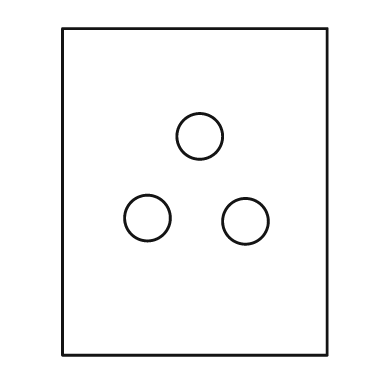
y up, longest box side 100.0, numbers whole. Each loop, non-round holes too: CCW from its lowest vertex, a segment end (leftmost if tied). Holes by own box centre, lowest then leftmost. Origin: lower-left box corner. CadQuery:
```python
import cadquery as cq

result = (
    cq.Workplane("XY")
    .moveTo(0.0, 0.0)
    .lineTo(81.0, 0.0)
    .lineTo(81.0, 100.0)
    .lineTo(0.0, 100.0)
    .close()
    .moveTo(56.0, 41.0)
    .circle(7.0)
    .moveTo(26.0, 42.0)
    .circle(7.0)
    .moveTo(42.0, 67.0)
    .circle(7.0)
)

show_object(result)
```